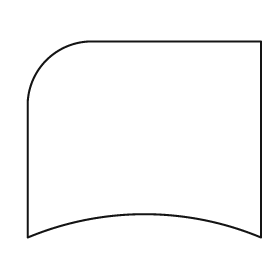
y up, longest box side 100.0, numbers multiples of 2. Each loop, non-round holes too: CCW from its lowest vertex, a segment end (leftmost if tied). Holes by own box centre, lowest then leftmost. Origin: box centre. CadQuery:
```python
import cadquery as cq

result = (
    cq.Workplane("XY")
    .moveTo(-50.0, -42.0)
    .threePointArc((0.0, -32.0), (50.0, -42.0))
    .lineTo(50.0, 42.0)
    .lineTo(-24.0, 42.0)
    .threePointArc((-42.0, 34.0), (-50.0, 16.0))
    .close()
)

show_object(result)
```